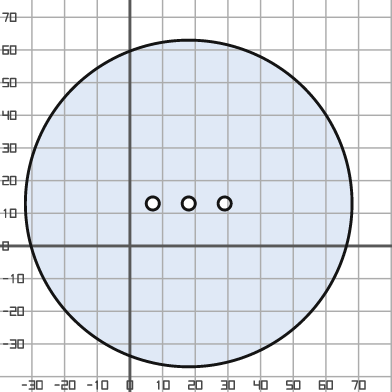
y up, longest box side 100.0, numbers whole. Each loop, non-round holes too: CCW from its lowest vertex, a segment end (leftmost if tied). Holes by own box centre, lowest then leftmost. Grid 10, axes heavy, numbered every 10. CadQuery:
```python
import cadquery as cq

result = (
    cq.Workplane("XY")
    .moveTo(18.0, 13.0)
    .circle(50.0)
    .moveTo(7.0, 13.0)
    .circle(2.0)
    .moveTo(18.0, 13.0)
    .circle(2.0)
    .moveTo(29.0, 13.0)
    .circle(2.0)
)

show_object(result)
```